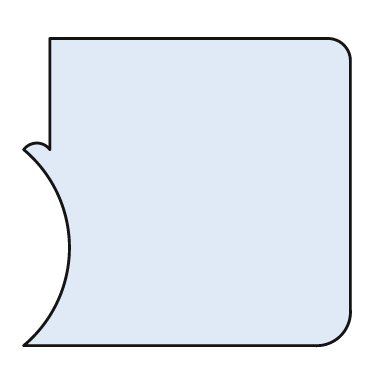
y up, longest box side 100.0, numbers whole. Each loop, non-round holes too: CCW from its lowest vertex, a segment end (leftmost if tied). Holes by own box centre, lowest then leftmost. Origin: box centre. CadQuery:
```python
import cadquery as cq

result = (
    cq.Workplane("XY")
    .moveTo(-50.0, -47.0)
    .lineTo(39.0, -47.0)
    .threePointArc((47.0, -44.0), (50.0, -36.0))
    .lineTo(50.0, 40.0)
    .threePointArc((48.0, 45.0), (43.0, 47.0))
    .lineTo(-42.0, 47.0)
    .lineTo(-42.0, 13.0)
    .threePointArc((-46.0, 15.0), (-50.0, 13.0))
    .threePointArc((-36.0, -17.0), (-50.0, -47.0))
    .close()
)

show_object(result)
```